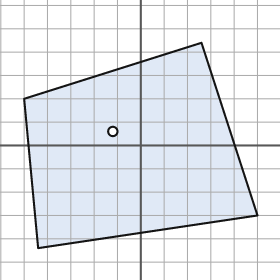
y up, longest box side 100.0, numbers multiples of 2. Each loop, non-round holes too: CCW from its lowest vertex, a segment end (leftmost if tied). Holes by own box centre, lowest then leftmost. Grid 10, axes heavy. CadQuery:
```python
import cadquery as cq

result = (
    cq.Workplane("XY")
    .moveTo(-44.0, -44.0)
    .lineTo(50.0, -30.0)
    .lineTo(26.0, 44.0)
    .lineTo(-50.0, 20.0)
    .close()
    .moveTo(-12.0, 6.0)
    .circle(2.0)
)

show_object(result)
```